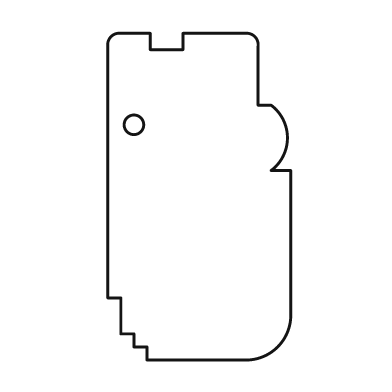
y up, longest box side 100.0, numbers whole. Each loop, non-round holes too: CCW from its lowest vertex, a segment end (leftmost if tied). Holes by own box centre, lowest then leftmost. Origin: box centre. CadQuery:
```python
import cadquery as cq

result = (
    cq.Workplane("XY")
    .moveTo(-16.0, -50.0)
    .lineTo(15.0, -50.0)
    .threePointArc((24.0, -46.0), (28.0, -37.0))
    .lineTo(28.0, 8.0)
    .lineTo(22.0, 8.0)
    .threePointArc((27.0, 18.0), (22.0, 28.0))
    .lineTo(18.0, 28.0)
    .lineTo(18.0, 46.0)
    .threePointArc((17.0, 49.0), (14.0, 50.0))
    .lineTo(-5.0, 50.0)
    .lineTo(-5.0, 45.0)
    .lineTo(-15.0, 45.0)
    .lineTo(-15.0, 50.0)
    .lineTo(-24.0, 50.0)
    .threePointArc((-27.0, 49.0), (-28.0, 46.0))
    .lineTo(-28.0, -31.0)
    .lineTo(-24.0, -31.0)
    .lineTo(-24.0, -42.0)
    .lineTo(-20.0, -42.0)
    .lineTo(-20.0, -46.0)
    .lineTo(-16.0, -46.0)
    .close()
    .moveTo(-20.0, 22.0)
    .circle(3.0)
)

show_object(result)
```